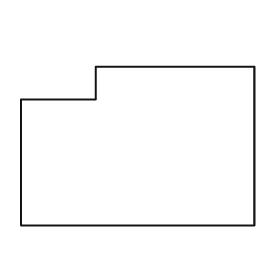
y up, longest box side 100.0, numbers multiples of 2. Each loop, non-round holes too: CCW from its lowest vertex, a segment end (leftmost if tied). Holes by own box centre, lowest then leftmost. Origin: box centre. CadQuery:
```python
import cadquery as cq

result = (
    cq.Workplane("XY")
    .moveTo(-50.0, -34.0)
    .lineTo(50.0, -34.0)
    .lineTo(50.0, 34.0)
    .lineTo(-18.0, 34.0)
    .lineTo(-18.0, 20.0)
    .lineTo(-50.0, 20.0)
    .close()
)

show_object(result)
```